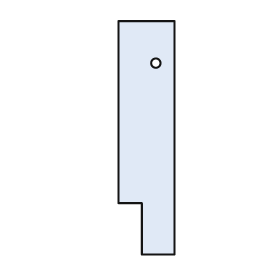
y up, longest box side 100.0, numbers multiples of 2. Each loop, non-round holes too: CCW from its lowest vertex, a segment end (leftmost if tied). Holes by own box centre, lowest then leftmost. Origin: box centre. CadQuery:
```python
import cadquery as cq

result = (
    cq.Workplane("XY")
    .moveTo(-2.0, -50.0)
    .lineTo(12.0, -50.0)
    .lineTo(12.0, 50.0)
    .lineTo(-12.0, 50.0)
    .lineTo(-12.0, -28.0)
    .lineTo(-2.0, -28.0)
    .close()
    .moveTo(4.0, 32.0)
    .circle(2.0)
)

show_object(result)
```